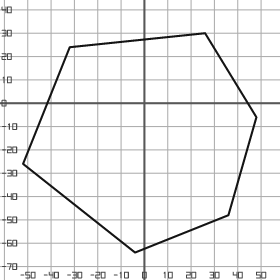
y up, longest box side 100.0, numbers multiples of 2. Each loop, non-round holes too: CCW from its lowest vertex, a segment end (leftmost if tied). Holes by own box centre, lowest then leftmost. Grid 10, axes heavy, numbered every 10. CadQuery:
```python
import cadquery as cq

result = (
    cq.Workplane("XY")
    .moveTo(-4.0, -64.0)
    .lineTo(36.0, -48.0)
    .lineTo(48.0, -6.0)
    .lineTo(26.0, 30.0)
    .lineTo(-32.0, 24.0)
    .lineTo(-52.0, -26.0)
    .close()
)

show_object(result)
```